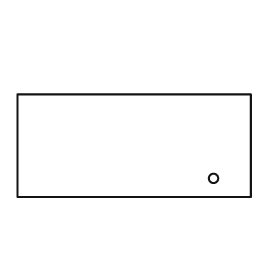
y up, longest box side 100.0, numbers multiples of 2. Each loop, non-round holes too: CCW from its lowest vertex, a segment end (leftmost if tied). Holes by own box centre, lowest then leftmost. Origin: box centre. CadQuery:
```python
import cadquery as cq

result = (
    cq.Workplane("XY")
    .moveTo(-50.0, -22.0)
    .lineTo(50.0, -22.0)
    .lineTo(50.0, 22.0)
    .lineTo(-50.0, 22.0)
    .close()
    .moveTo(34.0, -14.0)
    .circle(2.0)
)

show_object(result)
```